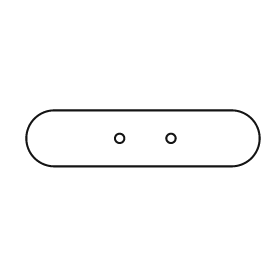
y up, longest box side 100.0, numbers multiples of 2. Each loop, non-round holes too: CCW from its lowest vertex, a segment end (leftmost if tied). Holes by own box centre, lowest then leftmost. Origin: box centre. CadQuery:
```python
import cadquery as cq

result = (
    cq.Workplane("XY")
    .moveTo(-38.0, -12.0)
    .lineTo(38.0, -12.0)
    .threePointArc((50.0, 0.0), (38.0, 12.0))
    .lineTo(-38.0, 12.0)
    .threePointArc((-50.0, 0.0), (-38.0, -12.0))
    .close()
    .moveTo(-10.0, 0.0)
    .circle(2.0)
    .moveTo(12.0, 0.0)
    .circle(2.0)
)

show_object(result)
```